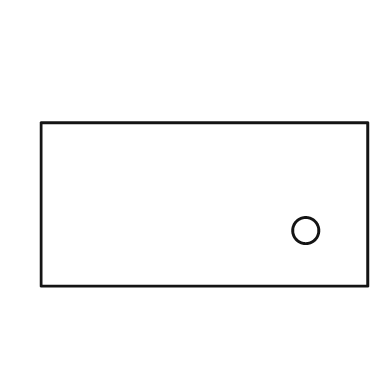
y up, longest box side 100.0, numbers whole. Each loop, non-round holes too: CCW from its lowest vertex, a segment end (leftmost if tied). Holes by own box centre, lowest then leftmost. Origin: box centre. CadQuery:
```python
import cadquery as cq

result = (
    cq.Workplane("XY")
    .moveTo(-50.0, -25.0)
    .lineTo(50.0, -25.0)
    .lineTo(50.0, 25.0)
    .lineTo(-50.0, 25.0)
    .close()
    .moveTo(31.0, -8.0)
    .circle(4.0)
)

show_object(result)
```